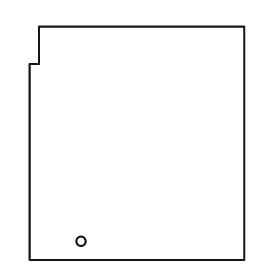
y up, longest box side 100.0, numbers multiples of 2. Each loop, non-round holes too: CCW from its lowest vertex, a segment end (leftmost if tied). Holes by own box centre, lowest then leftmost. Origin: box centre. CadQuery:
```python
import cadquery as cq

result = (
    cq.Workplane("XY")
    .moveTo(-46.0, -50.0)
    .lineTo(46.0, -50.0)
    .lineTo(46.0, 50.0)
    .lineTo(-42.0, 50.0)
    .lineTo(-42.0, 34.0)
    .lineTo(-46.0, 34.0)
    .close()
    .moveTo(-24.0, -42.0)
    .circle(2.0)
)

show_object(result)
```